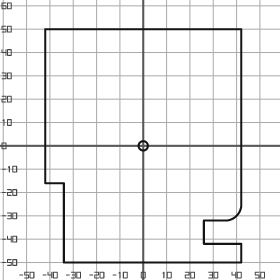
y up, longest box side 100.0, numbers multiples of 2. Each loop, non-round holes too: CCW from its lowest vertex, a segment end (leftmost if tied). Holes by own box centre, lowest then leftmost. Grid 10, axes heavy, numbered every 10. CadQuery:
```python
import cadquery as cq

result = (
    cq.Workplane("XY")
    .moveTo(-34.0, -50.0)
    .lineTo(42.0, -50.0)
    .lineTo(42.0, -42.0)
    .lineTo(26.0, -42.0)
    .lineTo(26.0, -32.0)
    .lineTo(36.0, -32.0)
    .threePointArc((40.0, -30.0), (42.0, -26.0))
    .lineTo(42.0, 50.0)
    .lineTo(-42.0, 50.0)
    .lineTo(-42.0, -16.0)
    .lineTo(-34.0, -16.0)
    .close()
    .moveTo(0.0, 0.0)
    .circle(2.0)
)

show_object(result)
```